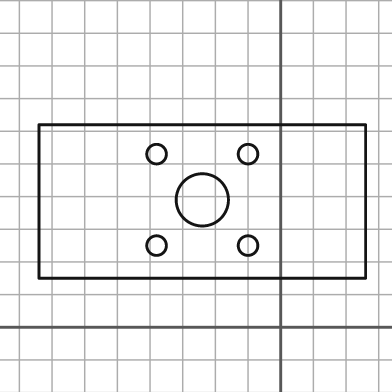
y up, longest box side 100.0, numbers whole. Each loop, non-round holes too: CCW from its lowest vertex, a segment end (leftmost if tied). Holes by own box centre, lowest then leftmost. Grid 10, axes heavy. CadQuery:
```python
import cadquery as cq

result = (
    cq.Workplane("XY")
    .moveTo(-74.0, 15.0)
    .lineTo(26.0, 15.0)
    .lineTo(26.0, 62.0)
    .lineTo(-74.0, 62.0)
    .close()
    .moveTo(-38.0, 25.0)
    .circle(3.0)
    .moveTo(-10.0, 25.0)
    .circle(3.0)
    .moveTo(-24.0, 39.0)
    .circle(8.0)
    .moveTo(-38.0, 53.0)
    .circle(3.0)
    .moveTo(-10.0, 53.0)
    .circle(3.0)
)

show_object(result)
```